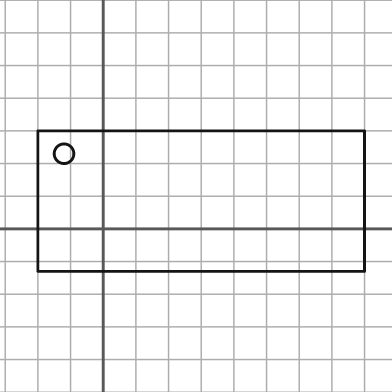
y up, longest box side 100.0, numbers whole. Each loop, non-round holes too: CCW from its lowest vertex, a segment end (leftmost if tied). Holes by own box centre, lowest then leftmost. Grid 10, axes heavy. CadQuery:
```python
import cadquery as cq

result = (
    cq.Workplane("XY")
    .moveTo(-20.0, -13.0)
    .lineTo(80.0, -13.0)
    .lineTo(80.0, 30.0)
    .lineTo(-20.0, 30.0)
    .close()
    .moveTo(-12.0, 23.0)
    .circle(3.0)
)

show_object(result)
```